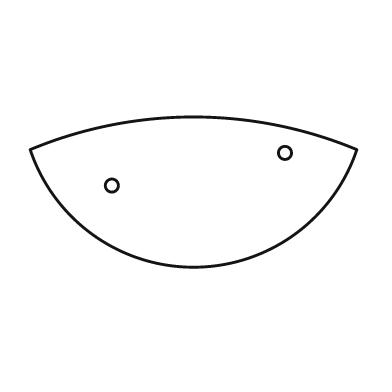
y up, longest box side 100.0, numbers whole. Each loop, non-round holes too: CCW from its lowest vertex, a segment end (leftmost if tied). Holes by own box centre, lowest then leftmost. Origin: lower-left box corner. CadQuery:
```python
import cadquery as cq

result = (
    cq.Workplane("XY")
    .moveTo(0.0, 36.0)
    .threePointArc((50.0, 0.0), (100.0, 36.0))
    .threePointArc((50.0, 46.0), (0.0, 36.0))
    .close()
    .moveTo(25.0, 25.0)
    .circle(2.0)
    .moveTo(78.0, 35.0)
    .circle(2.0)
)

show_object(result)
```